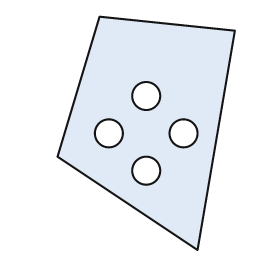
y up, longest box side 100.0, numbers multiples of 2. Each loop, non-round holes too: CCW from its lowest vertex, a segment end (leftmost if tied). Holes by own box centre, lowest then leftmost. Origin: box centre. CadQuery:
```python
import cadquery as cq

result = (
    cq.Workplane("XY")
    .moveTo(22.0, -50.0)
    .lineTo(38.0, 44.0)
    .lineTo(-20.0, 50.0)
    .lineTo(-38.0, -10.0)
    .close()
    .moveTo(0.0, -16.0)
    .circle(6.0)
    .moveTo(-16.0, 0.0)
    .circle(6.0)
    .moveTo(16.0, 0.0)
    .circle(6.0)
    .moveTo(0.0, 16.0)
    .circle(6.0)
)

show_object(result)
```